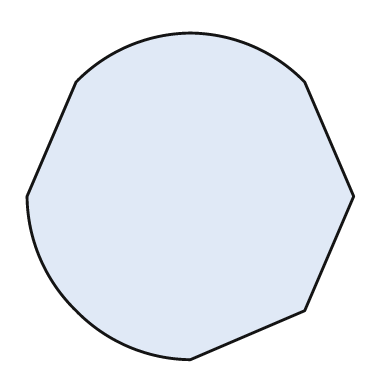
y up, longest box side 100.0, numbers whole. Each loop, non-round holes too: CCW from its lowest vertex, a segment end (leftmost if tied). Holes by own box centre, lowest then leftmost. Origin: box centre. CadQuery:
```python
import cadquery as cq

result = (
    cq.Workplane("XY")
    .moveTo(0.0, -50.0)
    .lineTo(35.0, -35.0)
    .lineTo(50.0, 0.0)
    .lineTo(35.0, 35.0)
    .threePointArc((19.0, 46.0), (0.0, 50.0))
    .threePointArc((-19.0, 46.0), (-35.0, 35.0))
    .lineTo(-50.0, 0.0)
    .threePointArc((-46.0, -19.0), (-35.0, -35.0))
    .threePointArc((-19.0, -46.0), (0.0, -50.0))
    .close()
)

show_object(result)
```